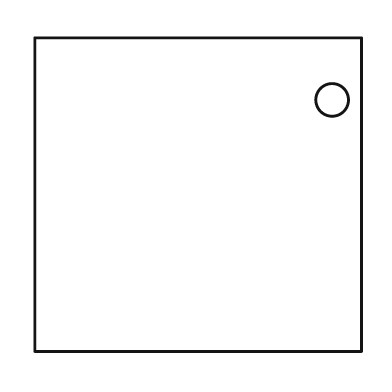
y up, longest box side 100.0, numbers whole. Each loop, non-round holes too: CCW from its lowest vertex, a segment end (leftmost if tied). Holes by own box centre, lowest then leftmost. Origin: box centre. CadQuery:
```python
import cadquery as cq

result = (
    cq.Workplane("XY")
    .moveTo(-50.0, -48.0)
    .lineTo(50.0, -48.0)
    .lineTo(50.0, 48.0)
    .lineTo(-50.0, 48.0)
    .close()
    .moveTo(41.0, 29.0)
    .circle(5.0)
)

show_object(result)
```